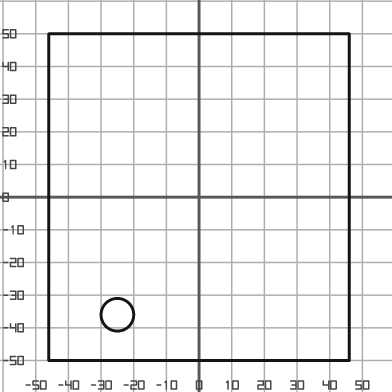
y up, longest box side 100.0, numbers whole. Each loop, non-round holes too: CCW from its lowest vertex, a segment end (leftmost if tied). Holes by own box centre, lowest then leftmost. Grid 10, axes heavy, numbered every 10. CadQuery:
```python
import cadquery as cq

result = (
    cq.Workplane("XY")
    .moveTo(-46.0, -50.0)
    .lineTo(46.0, -50.0)
    .lineTo(46.0, 50.0)
    .lineTo(-46.0, 50.0)
    .close()
    .moveTo(-25.0, -36.0)
    .circle(5.0)
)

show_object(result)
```